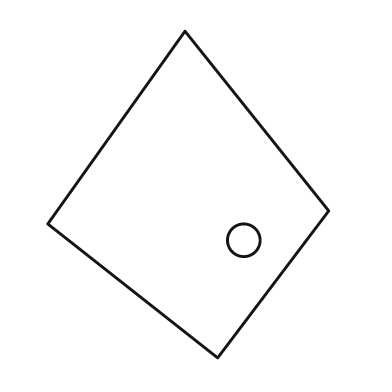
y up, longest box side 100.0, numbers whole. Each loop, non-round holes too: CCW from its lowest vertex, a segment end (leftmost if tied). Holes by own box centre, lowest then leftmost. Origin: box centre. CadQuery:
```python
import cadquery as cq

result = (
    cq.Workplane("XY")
    .moveTo(9.0, -50.0)
    .lineTo(43.0, -5.0)
    .lineTo(-1.0, 50.0)
    .lineTo(-43.0, -9.0)
    .close()
    .moveTo(17.0, -14.0)
    .circle(5.0)
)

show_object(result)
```